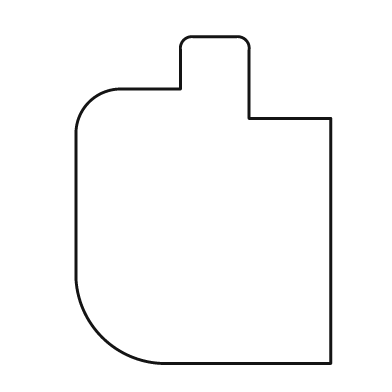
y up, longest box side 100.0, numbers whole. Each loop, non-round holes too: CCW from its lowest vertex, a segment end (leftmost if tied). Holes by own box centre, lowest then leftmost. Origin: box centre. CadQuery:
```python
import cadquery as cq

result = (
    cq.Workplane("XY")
    .moveTo(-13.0, -50.0)
    .lineTo(39.0, -50.0)
    .lineTo(39.0, 25.0)
    .lineTo(14.0, 25.0)
    .lineTo(14.0, 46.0)
    .threePointArc((13.0, 49.0), (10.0, 50.0))
    .lineTo(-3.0, 50.0)
    .threePointArc((-6.0, 49.0), (-7.0, 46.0))
    .lineTo(-7.0, 34.0)
    .lineTo(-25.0, 34.0)
    .threePointArc((-35.0, 30.0), (-39.0, 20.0))
    .lineTo(-39.0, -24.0)
    .threePointArc((-31.0, -42.0), (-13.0, -50.0))
    .close()
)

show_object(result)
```